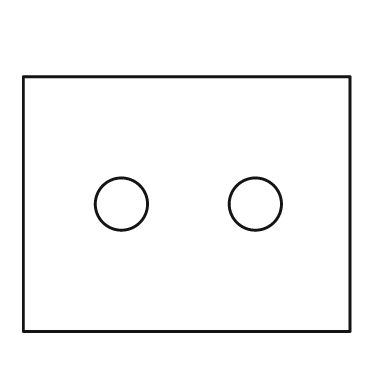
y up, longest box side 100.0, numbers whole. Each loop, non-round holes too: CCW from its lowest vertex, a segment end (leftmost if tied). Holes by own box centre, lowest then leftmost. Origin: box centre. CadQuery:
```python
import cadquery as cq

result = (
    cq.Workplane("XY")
    .moveTo(-50.0, -39.0)
    .lineTo(50.0, -39.0)
    .lineTo(50.0, 39.0)
    .lineTo(-50.0, 39.0)
    .close()
    .moveTo(-20.0, 0.0)
    .circle(8.0)
    .moveTo(21.0, 0.0)
    .circle(8.0)
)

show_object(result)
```